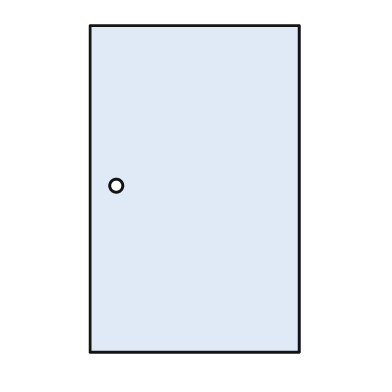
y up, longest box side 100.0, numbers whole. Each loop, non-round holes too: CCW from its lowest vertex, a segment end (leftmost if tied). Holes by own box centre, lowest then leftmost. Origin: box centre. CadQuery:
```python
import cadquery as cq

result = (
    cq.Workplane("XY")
    .moveTo(-32.0, -50.0)
    .lineTo(32.0, -50.0)
    .lineTo(32.0, 50.0)
    .lineTo(-32.0, 50.0)
    .close()
    .moveTo(-24.0, 1.0)
    .circle(2.0)
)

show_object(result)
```